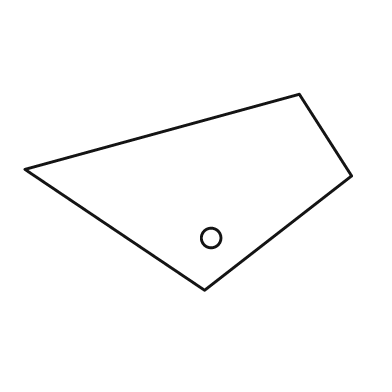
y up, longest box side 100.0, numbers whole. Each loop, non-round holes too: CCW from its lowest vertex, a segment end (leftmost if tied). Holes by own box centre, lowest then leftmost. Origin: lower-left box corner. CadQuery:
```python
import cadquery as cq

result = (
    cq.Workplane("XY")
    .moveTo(55.0, 0.0)
    .lineTo(100.0, 35.0)
    .lineTo(84.0, 60.0)
    .lineTo(0.0, 37.0)
    .close()
    .moveTo(57.0, 16.0)
    .circle(3.0)
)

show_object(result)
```